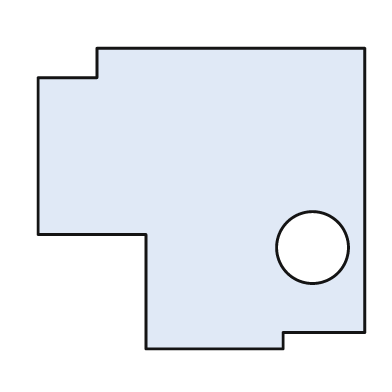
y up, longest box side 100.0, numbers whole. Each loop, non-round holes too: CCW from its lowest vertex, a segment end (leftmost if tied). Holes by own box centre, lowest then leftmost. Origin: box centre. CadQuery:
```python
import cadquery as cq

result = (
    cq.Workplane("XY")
    .moveTo(-17.0, -46.0)
    .lineTo(25.0, -46.0)
    .lineTo(25.0, -41.0)
    .lineTo(50.0, -41.0)
    .lineTo(50.0, 46.0)
    .lineTo(-32.0, 46.0)
    .lineTo(-32.0, 37.0)
    .lineTo(-50.0, 37.0)
    .lineTo(-50.0, -11.0)
    .lineTo(-17.0, -11.0)
    .close()
    .moveTo(34.0, -15.0)
    .circle(11.0)
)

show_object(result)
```